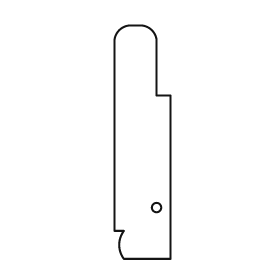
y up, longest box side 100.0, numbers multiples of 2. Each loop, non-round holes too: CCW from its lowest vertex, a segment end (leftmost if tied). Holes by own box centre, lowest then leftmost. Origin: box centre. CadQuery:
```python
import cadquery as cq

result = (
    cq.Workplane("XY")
    .moveTo(-8.0, -50.0)
    .lineTo(12.0, -50.0)
    .lineTo(12.0, 20.0)
    .lineTo(6.0, 20.0)
    .lineTo(6.0, 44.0)
    .threePointArc((4.0, 48.0), (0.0, 50.0))
    .lineTo(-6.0, 50.0)
    .threePointArc((-10.0, 48.0), (-12.0, 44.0))
    .lineTo(-12.0, -38.0)
    .lineTo(-8.0, -38.0)
    .threePointArc((-10.0, -44.0), (-8.0, -50.0))
    .close()
    .moveTo(6.0, -28.0)
    .circle(2.0)
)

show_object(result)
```